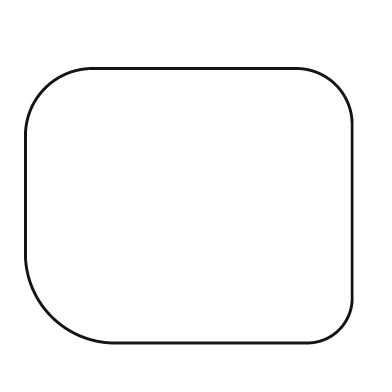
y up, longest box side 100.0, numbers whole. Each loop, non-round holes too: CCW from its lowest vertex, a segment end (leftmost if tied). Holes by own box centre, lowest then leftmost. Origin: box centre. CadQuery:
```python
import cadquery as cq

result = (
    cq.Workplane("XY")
    .moveTo(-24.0, -42.0)
    .lineTo(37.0, -42.0)
    .threePointArc((46.0, -38.0), (50.0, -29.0))
    .lineTo(50.0, 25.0)
    .threePointArc((45.0, 37.0), (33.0, 42.0))
    .lineTo(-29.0, 42.0)
    .threePointArc((-44.0, 36.0), (-50.0, 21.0))
    .lineTo(-50.0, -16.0)
    .threePointArc((-42.0, -34.0), (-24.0, -42.0))
    .close()
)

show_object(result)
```